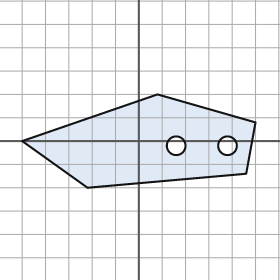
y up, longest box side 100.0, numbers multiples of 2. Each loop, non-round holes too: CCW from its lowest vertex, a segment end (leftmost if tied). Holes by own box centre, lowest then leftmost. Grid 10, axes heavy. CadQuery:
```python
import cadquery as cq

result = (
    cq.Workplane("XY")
    .moveTo(-22.0, -20.0)
    .lineTo(46.0, -14.0)
    .lineTo(50.0, 8.0)
    .lineTo(8.0, 20.0)
    .lineTo(-50.0, 0.0)
    .close()
    .moveTo(16.0, -2.0)
    .circle(4.0)
    .moveTo(38.0, -2.0)
    .circle(4.0)
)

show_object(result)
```